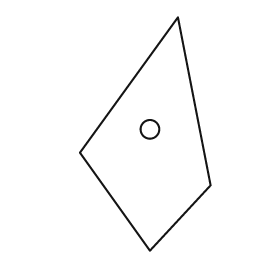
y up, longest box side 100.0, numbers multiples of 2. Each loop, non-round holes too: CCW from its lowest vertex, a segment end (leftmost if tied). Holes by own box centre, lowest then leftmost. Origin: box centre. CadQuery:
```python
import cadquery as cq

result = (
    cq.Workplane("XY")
    .moveTo(2.0, -50.0)
    .lineTo(28.0, -22.0)
    .lineTo(14.0, 50.0)
    .lineTo(-28.0, -8.0)
    .close()
    .moveTo(2.0, 2.0)
    .circle(4.0)
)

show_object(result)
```